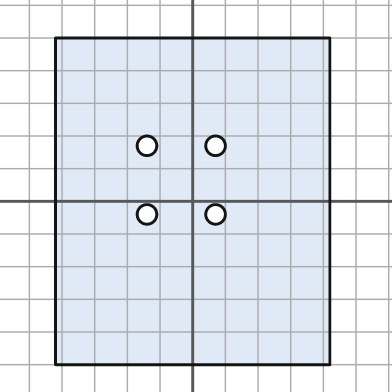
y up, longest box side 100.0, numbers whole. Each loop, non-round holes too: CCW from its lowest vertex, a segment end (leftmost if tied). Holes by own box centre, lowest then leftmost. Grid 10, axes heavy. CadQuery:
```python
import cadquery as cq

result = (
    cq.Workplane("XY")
    .moveTo(-42.0, -50.0)
    .lineTo(42.0, -50.0)
    .lineTo(42.0, 50.0)
    .lineTo(-42.0, 50.0)
    .close()
    .moveTo(-14.0, -4.0)
    .circle(3.0)
    .moveTo(7.0, -4.0)
    .circle(3.0)
    .moveTo(-14.0, 17.0)
    .circle(3.0)
    .moveTo(7.0, 17.0)
    .circle(3.0)
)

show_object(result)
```